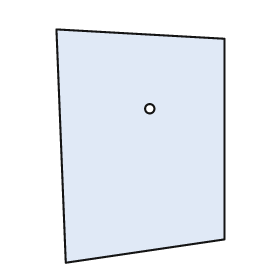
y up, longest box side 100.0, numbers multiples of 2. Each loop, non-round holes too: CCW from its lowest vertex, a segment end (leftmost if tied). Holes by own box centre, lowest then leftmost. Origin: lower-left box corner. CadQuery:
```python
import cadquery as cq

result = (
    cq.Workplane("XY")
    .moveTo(4.0, 0.0)
    .lineTo(72.0, 10.0)
    .lineTo(72.0, 96.0)
    .lineTo(0.0, 100.0)
    .close()
    .moveTo(40.0, 66.0)
    .circle(2.0)
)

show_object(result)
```